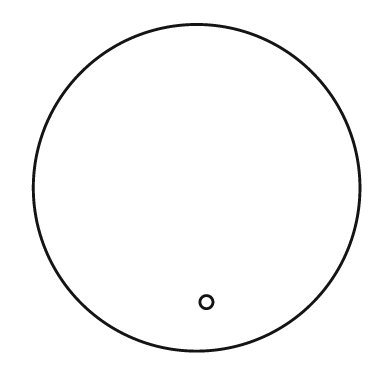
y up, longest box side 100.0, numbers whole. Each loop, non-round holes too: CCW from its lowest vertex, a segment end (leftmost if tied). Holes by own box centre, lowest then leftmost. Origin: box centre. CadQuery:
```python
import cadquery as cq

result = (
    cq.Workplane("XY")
    .moveTo(0.0, 0.0)
    .circle(50.0)
    .moveTo(3.0, -35.0)
    .circle(2.0)
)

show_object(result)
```